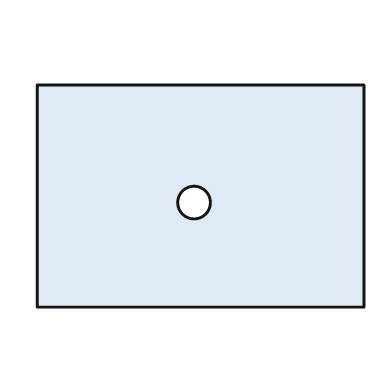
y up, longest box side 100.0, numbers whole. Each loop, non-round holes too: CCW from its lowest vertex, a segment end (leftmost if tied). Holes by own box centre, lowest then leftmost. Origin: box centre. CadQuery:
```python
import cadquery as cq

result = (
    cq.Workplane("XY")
    .moveTo(-50.0, -34.0)
    .lineTo(50.0, -34.0)
    .lineTo(50.0, 34.0)
    .lineTo(-50.0, 34.0)
    .close()
    .moveTo(-2.0, -2.0)
    .circle(5.0)
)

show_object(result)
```